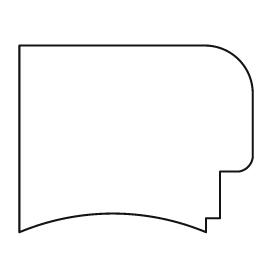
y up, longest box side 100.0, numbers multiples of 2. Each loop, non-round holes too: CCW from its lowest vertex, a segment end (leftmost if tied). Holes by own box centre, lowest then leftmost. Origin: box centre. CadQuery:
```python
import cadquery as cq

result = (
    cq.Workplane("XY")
    .moveTo(-50.0, -40.0)
    .threePointArc((-10.0, -32.0), (30.0, -40.0))
    .lineTo(30.0, -34.0)
    .lineTo(36.0, -34.0)
    .lineTo(36.0, -14.0)
    .lineTo(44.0, -14.0)
    .threePointArc((48.0, -12.0), (50.0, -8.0))
    .lineTo(50.0, 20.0)
    .threePointArc((44.0, 34.0), (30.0, 40.0))
    .lineTo(-50.0, 40.0)
    .close()
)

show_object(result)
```